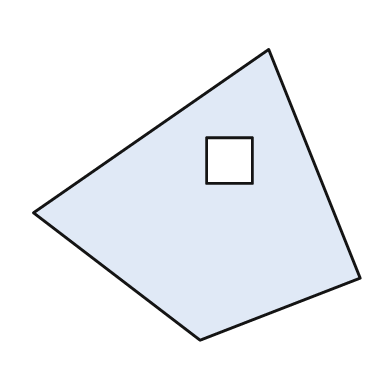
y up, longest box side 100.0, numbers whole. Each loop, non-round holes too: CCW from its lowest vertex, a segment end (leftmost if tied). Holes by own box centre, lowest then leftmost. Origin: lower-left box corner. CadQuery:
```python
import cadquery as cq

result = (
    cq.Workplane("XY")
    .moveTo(51.0, 0.0)
    .lineTo(100.0, 19.0)
    .lineTo(72.0, 89.0)
    .lineTo(0.0, 39.0)
    .close()
    .moveTo(53.0, 48.0)
    .lineTo(67.0, 48.0)
    .lineTo(67.0, 62.0)
    .lineTo(53.0, 62.0)
    .close()
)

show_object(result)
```